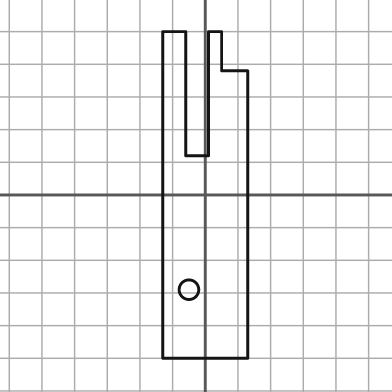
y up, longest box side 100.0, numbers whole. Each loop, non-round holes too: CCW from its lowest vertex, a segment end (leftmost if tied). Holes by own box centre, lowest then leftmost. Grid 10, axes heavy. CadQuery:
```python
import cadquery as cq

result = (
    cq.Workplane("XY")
    .moveTo(-13.0, -50.0)
    .lineTo(13.0, -50.0)
    .lineTo(13.0, 38.0)
    .lineTo(5.0, 38.0)
    .lineTo(5.0, 50.0)
    .lineTo(1.0, 50.0)
    .lineTo(1.0, 12.0)
    .lineTo(-6.0, 12.0)
    .lineTo(-6.0, 50.0)
    .lineTo(-13.0, 50.0)
    .close()
    .moveTo(-5.0, -29.0)
    .circle(3.0)
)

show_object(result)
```